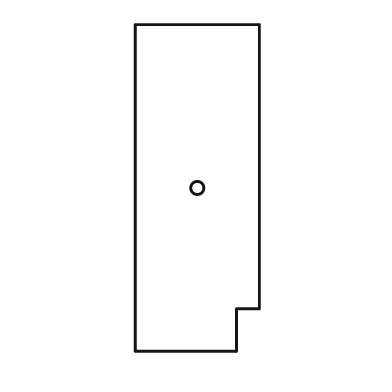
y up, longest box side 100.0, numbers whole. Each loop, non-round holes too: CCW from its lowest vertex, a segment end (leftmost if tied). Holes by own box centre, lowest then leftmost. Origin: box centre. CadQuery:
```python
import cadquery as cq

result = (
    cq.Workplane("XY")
    .moveTo(-19.0, -50.0)
    .lineTo(12.0, -50.0)
    .lineTo(12.0, -37.0)
    .lineTo(19.0, -37.0)
    .lineTo(19.0, 50.0)
    .lineTo(-19.0, 50.0)
    .close()
    .moveTo(0.0, 0.0)
    .circle(2.0)
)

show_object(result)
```